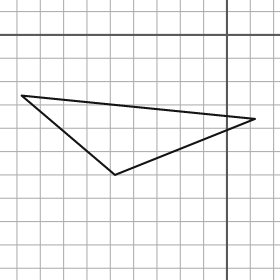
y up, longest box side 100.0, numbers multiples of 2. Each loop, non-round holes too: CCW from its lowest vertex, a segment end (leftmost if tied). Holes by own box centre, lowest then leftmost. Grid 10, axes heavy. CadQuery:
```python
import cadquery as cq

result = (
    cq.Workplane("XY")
    .moveTo(-48.0, -60.0)
    .lineTo(12.0, -36.0)
    .lineTo(-88.0, -26.0)
    .close()
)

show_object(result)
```